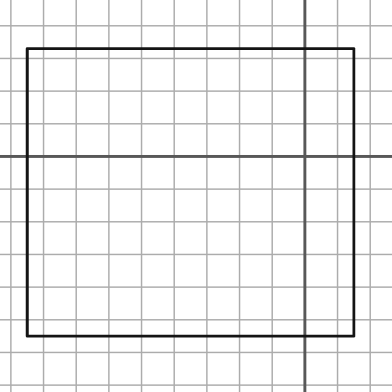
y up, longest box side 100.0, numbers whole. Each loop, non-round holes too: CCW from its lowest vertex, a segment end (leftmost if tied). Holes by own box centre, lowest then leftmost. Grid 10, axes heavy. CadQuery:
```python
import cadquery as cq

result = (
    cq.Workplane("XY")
    .moveTo(-85.0, -55.0)
    .lineTo(15.0, -55.0)
    .lineTo(15.0, 33.0)
    .lineTo(-85.0, 33.0)
    .close()
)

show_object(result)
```